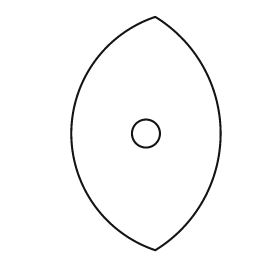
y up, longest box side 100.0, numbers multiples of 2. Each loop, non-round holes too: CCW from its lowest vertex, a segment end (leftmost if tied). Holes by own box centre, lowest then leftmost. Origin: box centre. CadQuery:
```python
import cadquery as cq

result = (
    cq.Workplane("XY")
    .moveTo(4.0, -50.0)
    .threePointArc((32.0, 0.0), (4.0, 50.0))
    .threePointArc((-32.0, 0.0), (4.0, -50.0))
    .close()
    .moveTo(0.0, 0.0)
    .circle(6.0)
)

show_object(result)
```